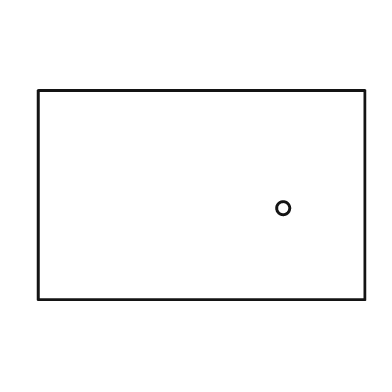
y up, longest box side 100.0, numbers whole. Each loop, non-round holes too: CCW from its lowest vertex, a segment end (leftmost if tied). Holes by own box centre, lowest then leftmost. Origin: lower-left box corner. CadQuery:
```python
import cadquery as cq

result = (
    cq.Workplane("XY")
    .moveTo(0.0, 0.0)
    .lineTo(100.0, 0.0)
    .lineTo(100.0, 64.0)
    .lineTo(0.0, 64.0)
    .close()
    .moveTo(75.0, 28.0)
    .circle(2.0)
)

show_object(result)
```